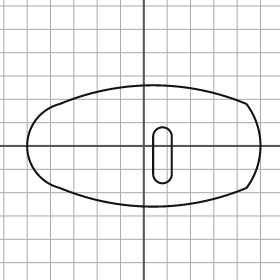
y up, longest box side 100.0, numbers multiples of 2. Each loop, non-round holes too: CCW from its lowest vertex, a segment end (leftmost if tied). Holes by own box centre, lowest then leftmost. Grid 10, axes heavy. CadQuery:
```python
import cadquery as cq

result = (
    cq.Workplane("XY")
    .moveTo(-36.0, -18.0)
    .threePointArc((4.0, -26.0), (44.0, -18.0))
    .threePointArc((50.0, 0.0), (44.0, 18.0))
    .threePointArc((4.0, 26.0), (-36.0, 18.0))
    .threePointArc((-50.0, 0.0), (-36.0, -18.0))
    .close()
    .moveTo(4.0, -12.0)
    .threePointArc((8.0, -16.0), (12.0, -12.0))
    .lineTo(12.0, 4.0)
    .threePointArc((8.0, 8.0), (4.0, 4.0))
    .close()
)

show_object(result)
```